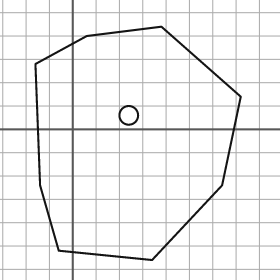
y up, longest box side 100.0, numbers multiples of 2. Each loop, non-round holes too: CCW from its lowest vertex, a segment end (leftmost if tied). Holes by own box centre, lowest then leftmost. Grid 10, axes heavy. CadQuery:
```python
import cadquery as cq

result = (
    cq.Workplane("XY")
    .moveTo(34.0, -56.0)
    .lineTo(64.0, -24.0)
    .lineTo(72.0, 14.0)
    .lineTo(38.0, 44.0)
    .lineTo(6.0, 40.0)
    .lineTo(-16.0, 28.0)
    .lineTo(-14.0, -24.0)
    .lineTo(-6.0, -52.0)
    .close()
    .moveTo(24.0, 6.0)
    .circle(4.0)
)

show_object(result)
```